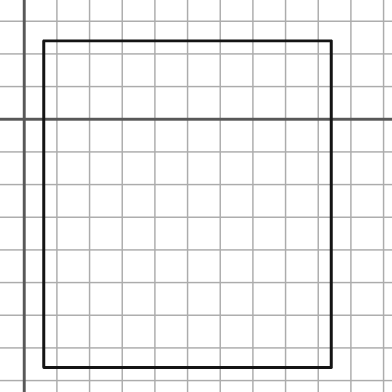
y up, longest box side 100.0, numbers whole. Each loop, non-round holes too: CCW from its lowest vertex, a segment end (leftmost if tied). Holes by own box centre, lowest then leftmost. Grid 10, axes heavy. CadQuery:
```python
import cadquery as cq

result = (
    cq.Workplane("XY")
    .moveTo(6.0, -76.0)
    .lineTo(94.0, -76.0)
    .lineTo(94.0, 24.0)
    .lineTo(6.0, 24.0)
    .close()
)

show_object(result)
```